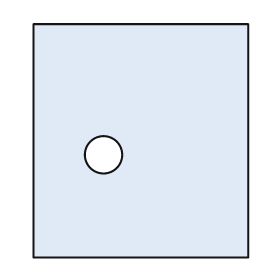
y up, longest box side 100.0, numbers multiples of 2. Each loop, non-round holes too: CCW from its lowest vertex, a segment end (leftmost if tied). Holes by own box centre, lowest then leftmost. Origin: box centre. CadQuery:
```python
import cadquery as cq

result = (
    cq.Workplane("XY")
    .moveTo(-46.0, -50.0)
    .lineTo(46.0, -50.0)
    .lineTo(46.0, 50.0)
    .lineTo(-46.0, 50.0)
    .close()
    .moveTo(-16.0, -6.0)
    .circle(8.0)
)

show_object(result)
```